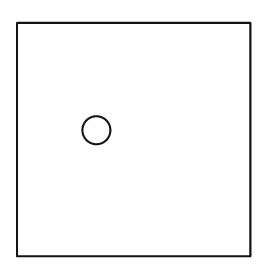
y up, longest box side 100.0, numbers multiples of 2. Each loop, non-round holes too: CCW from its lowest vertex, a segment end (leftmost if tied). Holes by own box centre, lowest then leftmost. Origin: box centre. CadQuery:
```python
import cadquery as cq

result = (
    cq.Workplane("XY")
    .moveTo(-50.0, -50.0)
    .lineTo(50.0, -50.0)
    .lineTo(50.0, 50.0)
    .lineTo(-50.0, 50.0)
    .close()
    .moveTo(-16.0, 4.0)
    .circle(6.0)
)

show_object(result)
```